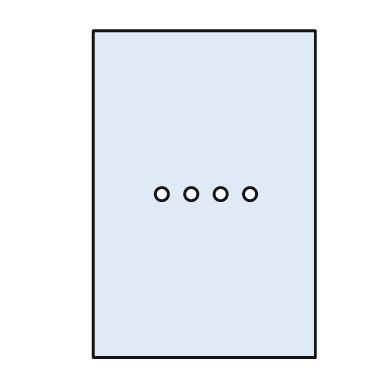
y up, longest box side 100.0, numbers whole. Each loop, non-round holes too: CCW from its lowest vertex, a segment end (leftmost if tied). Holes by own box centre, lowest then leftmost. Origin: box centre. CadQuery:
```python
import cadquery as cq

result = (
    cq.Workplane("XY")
    .moveTo(-34.0, -50.0)
    .lineTo(34.0, -50.0)
    .lineTo(34.0, 50.0)
    .lineTo(-34.0, 50.0)
    .close()
    .moveTo(-13.0, 0.0)
    .circle(2.0)
    .moveTo(-4.0, 0.0)
    .circle(2.0)
    .moveTo(5.0, 0.0)
    .circle(2.0)
    .moveTo(14.0, 0.0)
    .circle(2.0)
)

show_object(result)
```